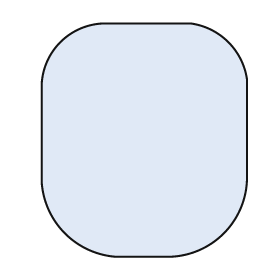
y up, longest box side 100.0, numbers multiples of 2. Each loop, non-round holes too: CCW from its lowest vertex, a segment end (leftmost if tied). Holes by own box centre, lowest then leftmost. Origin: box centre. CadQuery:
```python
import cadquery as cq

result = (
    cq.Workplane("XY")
    .moveTo(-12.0, -50.0)
    .lineTo(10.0, -50.0)
    .threePointArc((34.0, -40.0), (44.0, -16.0))
    .lineTo(44.0, 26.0)
    .threePointArc((36.0, 42.0), (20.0, 50.0))
    .lineTo(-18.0, 50.0)
    .threePointArc((-36.0, 42.0), (-44.0, 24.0))
    .lineTo(-44.0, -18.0)
    .threePointArc((-34.0, -40.0), (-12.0, -50.0))
    .close()
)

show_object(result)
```